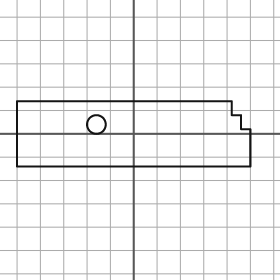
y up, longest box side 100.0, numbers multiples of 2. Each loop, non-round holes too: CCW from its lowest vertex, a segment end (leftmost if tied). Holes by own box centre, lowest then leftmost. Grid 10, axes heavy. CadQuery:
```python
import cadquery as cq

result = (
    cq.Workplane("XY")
    .moveTo(-50.0, -14.0)
    .lineTo(50.0, -14.0)
    .lineTo(50.0, 2.0)
    .lineTo(46.0, 2.0)
    .lineTo(46.0, 8.0)
    .lineTo(42.0, 8.0)
    .lineTo(42.0, 14.0)
    .lineTo(-50.0, 14.0)
    .close()
    .moveTo(-16.0, 4.0)
    .circle(4.0)
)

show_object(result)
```